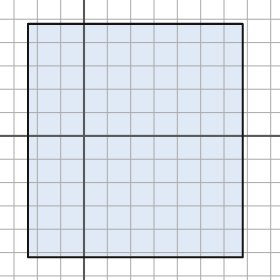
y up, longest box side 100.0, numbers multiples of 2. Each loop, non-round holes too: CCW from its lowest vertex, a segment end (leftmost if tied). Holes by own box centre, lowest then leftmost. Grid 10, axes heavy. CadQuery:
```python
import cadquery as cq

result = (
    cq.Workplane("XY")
    .moveTo(-24.0, -52.0)
    .lineTo(68.0, -52.0)
    .lineTo(68.0, 48.0)
    .lineTo(-24.0, 48.0)
    .close()
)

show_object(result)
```